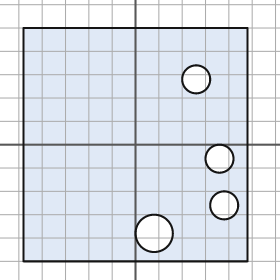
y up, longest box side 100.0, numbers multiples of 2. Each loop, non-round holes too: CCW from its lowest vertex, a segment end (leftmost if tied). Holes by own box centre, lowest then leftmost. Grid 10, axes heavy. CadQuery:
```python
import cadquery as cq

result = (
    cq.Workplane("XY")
    .moveTo(-48.0, -50.0)
    .lineTo(48.0, -50.0)
    .lineTo(48.0, 50.0)
    .lineTo(-48.0, 50.0)
    .close()
    .moveTo(8.0, -38.0)
    .circle(8.0)
    .moveTo(38.0, -26.0)
    .circle(6.0)
    .moveTo(36.0, -6.0)
    .circle(6.0)
    .moveTo(26.0, 28.0)
    .circle(6.0)
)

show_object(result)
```